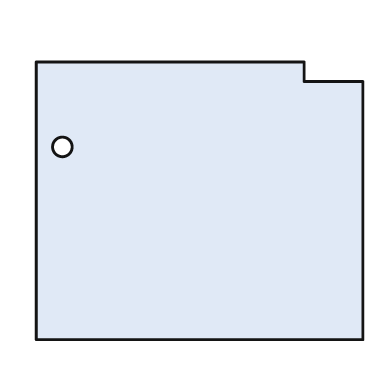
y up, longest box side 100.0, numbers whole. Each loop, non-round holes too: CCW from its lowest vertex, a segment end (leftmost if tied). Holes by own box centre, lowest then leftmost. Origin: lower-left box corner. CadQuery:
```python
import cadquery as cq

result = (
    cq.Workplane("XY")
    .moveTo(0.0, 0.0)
    .lineTo(100.0, 0.0)
    .lineTo(100.0, 79.0)
    .lineTo(82.0, 79.0)
    .lineTo(82.0, 85.0)
    .lineTo(0.0, 85.0)
    .close()
    .moveTo(8.0, 59.0)
    .circle(3.0)
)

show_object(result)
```